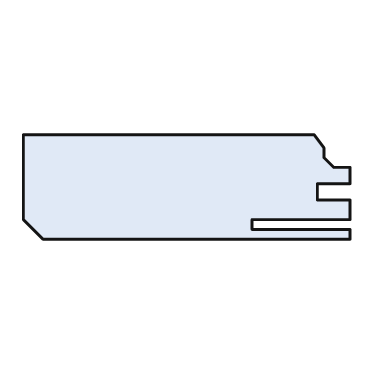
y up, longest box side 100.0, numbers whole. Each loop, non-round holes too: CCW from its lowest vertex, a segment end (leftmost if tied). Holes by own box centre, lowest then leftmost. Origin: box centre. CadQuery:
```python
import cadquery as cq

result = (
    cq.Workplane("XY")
    .moveTo(-44.0, -16.0)
    .lineTo(50.0, -16.0)
    .lineTo(50.0, -13.0)
    .lineTo(20.0, -13.0)
    .lineTo(20.0, -10.0)
    .lineTo(50.0, -10.0)
    .lineTo(50.0, -4.0)
    .lineTo(40.0, -4.0)
    .lineTo(40.0, 1.0)
    .lineTo(50.0, 1.0)
    .lineTo(50.0, 6.0)
    .lineTo(45.0, 6.0)
    .lineTo(42.0, 9.0)
    .lineTo(42.0, 12.0)
    .lineTo(39.0, 16.0)
    .lineTo(-50.0, 16.0)
    .lineTo(-50.0, -10.0)
    .close()
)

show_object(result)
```